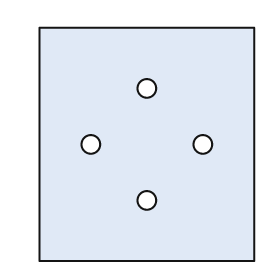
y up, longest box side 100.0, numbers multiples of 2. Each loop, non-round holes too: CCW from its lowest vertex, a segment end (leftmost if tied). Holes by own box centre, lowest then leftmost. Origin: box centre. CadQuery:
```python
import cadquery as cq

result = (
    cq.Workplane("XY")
    .moveTo(-46.0, -50.0)
    .lineTo(46.0, -50.0)
    .lineTo(46.0, 50.0)
    .lineTo(-46.0, 50.0)
    .close()
    .moveTo(0.0, -24.0)
    .circle(4.0)
    .moveTo(-24.0, 0.0)
    .circle(4.0)
    .moveTo(24.0, 0.0)
    .circle(4.0)
    .moveTo(0.0, 24.0)
    .circle(4.0)
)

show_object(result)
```